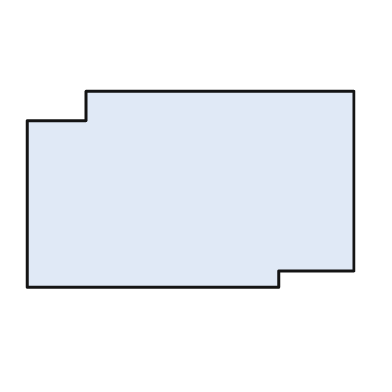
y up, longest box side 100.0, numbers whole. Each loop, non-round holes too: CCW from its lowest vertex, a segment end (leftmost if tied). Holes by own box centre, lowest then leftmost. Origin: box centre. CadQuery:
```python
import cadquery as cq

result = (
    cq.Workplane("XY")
    .moveTo(-50.0, -30.0)
    .lineTo(27.0, -30.0)
    .lineTo(27.0, -25.0)
    .lineTo(50.0, -25.0)
    .lineTo(50.0, 30.0)
    .lineTo(-32.0, 30.0)
    .lineTo(-32.0, 21.0)
    .lineTo(-50.0, 21.0)
    .close()
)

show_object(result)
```